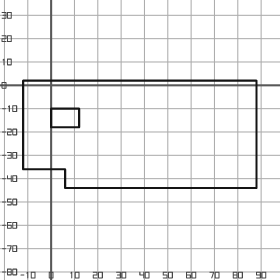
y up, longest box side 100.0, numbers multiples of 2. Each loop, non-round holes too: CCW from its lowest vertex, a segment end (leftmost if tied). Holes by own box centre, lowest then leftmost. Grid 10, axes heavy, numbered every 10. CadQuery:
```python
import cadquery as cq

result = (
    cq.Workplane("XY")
    .moveTo(6.0, -44.0)
    .lineTo(88.0, -44.0)
    .lineTo(88.0, 2.0)
    .lineTo(-12.0, 2.0)
    .lineTo(-12.0, -36.0)
    .lineTo(6.0, -36.0)
    .close()
    .moveTo(0.0, -18.0)
    .lineTo(12.0, -18.0)
    .lineTo(12.0, -10.0)
    .lineTo(0.0, -10.0)
    .close()
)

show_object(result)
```